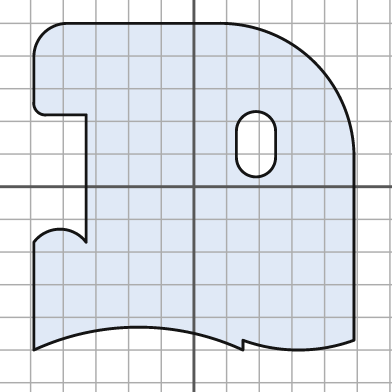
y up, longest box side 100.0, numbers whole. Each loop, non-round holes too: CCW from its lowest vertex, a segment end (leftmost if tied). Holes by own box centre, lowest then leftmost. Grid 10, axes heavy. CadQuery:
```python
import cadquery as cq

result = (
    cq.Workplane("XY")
    .moveTo(-49.0, -50.0)
    .threePointArc((-17.0, -43.0), (15.0, -50.0))
    .lineTo(15.0, -47.0)
    .threePointArc((32.0, -50.0), (49.0, -47.0))
    .lineTo(49.0, 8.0)
    .threePointArc((37.0, 38.0), (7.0, 50.0))
    .lineTo(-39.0, 50.0)
    .threePointArc((-46.0, 47.0), (-49.0, 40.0))
    .lineTo(-49.0, 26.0)
    .threePointArc((-48.0, 23.0), (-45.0, 22.0))
    .lineTo(-33.0, 22.0)
    .lineTo(-33.0, -17.0)
    .threePointArc((-41.0, -13.0), (-49.0, -17.0))
    .close()
    .moveTo(13.0, 9.0)
    .threePointArc((19.0, 3.0), (25.0, 9.0))
    .lineTo(25.0, 17.0)
    .threePointArc((19.0, 23.0), (13.0, 17.0))
    .close()
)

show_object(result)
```